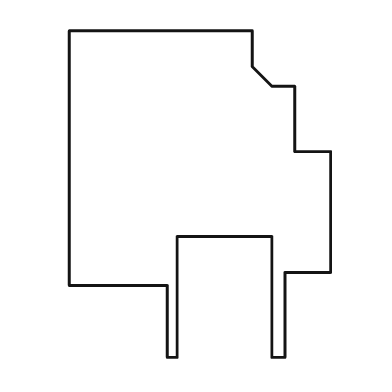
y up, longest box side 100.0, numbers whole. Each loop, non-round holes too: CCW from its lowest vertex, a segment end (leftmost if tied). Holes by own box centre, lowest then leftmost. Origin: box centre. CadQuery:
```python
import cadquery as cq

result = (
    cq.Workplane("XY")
    .moveTo(-10.0, -50.0)
    .lineTo(-7.0, -50.0)
    .lineTo(-7.0, -13.0)
    .lineTo(22.0, -13.0)
    .lineTo(22.0, -50.0)
    .lineTo(26.0, -50.0)
    .lineTo(26.0, -24.0)
    .lineTo(40.0, -24.0)
    .lineTo(40.0, 13.0)
    .lineTo(29.0, 13.0)
    .lineTo(29.0, 33.0)
    .lineTo(22.0, 33.0)
    .lineTo(16.0, 39.0)
    .lineTo(16.0, 50.0)
    .lineTo(-40.0, 50.0)
    .lineTo(-40.0, -28.0)
    .lineTo(-10.0, -28.0)
    .close()
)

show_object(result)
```